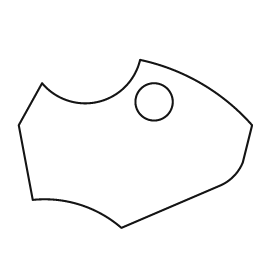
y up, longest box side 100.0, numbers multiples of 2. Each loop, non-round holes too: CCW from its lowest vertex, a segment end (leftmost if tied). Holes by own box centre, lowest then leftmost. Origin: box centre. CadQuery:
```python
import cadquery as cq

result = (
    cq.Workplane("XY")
    .moveTo(-6.0, -36.0)
    .lineTo(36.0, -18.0)
    .threePointArc((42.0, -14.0), (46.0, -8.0))
    .lineTo(50.0, 8.0)
    .threePointArc((28.0, 26.0), (2.0, 36.0))
    .threePointArc((-16.0, 18.0), (-40.0, 26.0))
    .lineTo(-50.0, 8.0)
    .lineTo(-44.0, -24.0)
    .threePointArc((-24.0, -26.0), (-6.0, -36.0))
    .close()
    .moveTo(8.0, 18.0)
    .circle(8.0)
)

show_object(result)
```